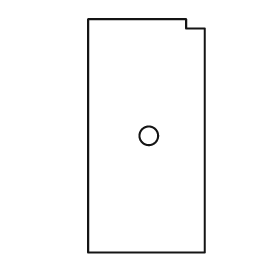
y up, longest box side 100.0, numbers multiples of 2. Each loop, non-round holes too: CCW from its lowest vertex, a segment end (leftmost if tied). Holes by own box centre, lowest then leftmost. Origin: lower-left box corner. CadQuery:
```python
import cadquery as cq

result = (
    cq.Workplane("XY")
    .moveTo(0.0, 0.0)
    .lineTo(50.0, 0.0)
    .lineTo(50.0, 96.0)
    .lineTo(42.0, 96.0)
    .lineTo(42.0, 100.0)
    .lineTo(0.0, 100.0)
    .close()
    .moveTo(26.0, 50.0)
    .circle(4.0)
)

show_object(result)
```